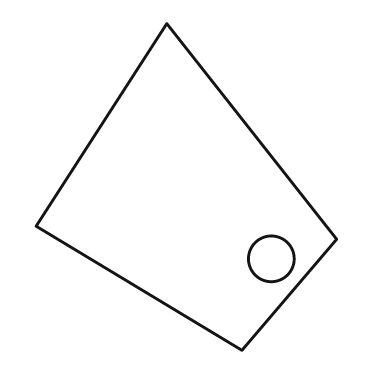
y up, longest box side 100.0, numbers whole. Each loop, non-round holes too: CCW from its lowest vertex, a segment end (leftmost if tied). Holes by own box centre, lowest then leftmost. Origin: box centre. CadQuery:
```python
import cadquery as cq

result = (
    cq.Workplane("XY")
    .moveTo(17.0, -50.0)
    .lineTo(46.0, -16.0)
    .lineTo(-6.0, 50.0)
    .lineTo(-46.0, -12.0)
    .close()
    .moveTo(26.0, -22.0)
    .circle(7.0)
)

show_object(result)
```